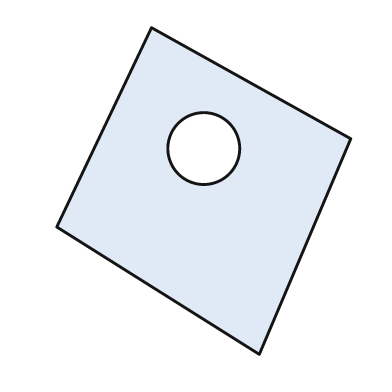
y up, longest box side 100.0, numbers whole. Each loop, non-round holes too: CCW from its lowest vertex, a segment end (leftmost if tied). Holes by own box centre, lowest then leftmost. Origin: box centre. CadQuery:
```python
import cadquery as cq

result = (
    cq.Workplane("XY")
    .moveTo(17.0, -50.0)
    .lineTo(45.0, 16.0)
    .lineTo(-16.0, 50.0)
    .lineTo(-45.0, -11.0)
    .close()
    .moveTo(0.0, 13.0)
    .circle(11.0)
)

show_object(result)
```